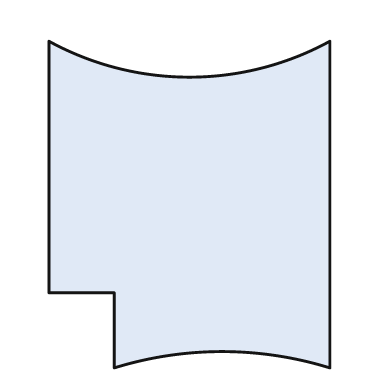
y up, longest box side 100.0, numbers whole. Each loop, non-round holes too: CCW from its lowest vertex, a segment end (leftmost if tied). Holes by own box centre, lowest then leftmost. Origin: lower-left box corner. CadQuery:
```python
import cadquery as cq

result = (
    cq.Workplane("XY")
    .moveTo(20.0, 0.0)
    .threePointArc((53.0, 5.0), (86.0, 0.0))
    .lineTo(86.0, 100.0)
    .threePointArc((43.0, 89.0), (0.0, 100.0))
    .lineTo(0.0, 23.0)
    .lineTo(20.0, 23.0)
    .close()
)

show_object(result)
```